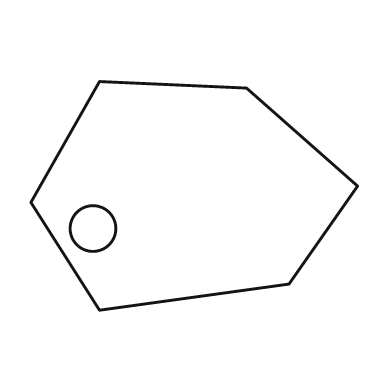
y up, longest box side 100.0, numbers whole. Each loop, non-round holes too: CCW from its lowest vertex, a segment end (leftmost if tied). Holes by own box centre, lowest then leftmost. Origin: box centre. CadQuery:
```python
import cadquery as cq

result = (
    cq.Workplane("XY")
    .moveTo(-29.0, -35.0)
    .lineTo(29.0, -27.0)
    .lineTo(50.0, 3.0)
    .lineTo(16.0, 33.0)
    .lineTo(-29.0, 35.0)
    .lineTo(-50.0, -2.0)
    .close()
    .moveTo(-31.0, -10.0)
    .circle(7.0)
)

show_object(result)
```